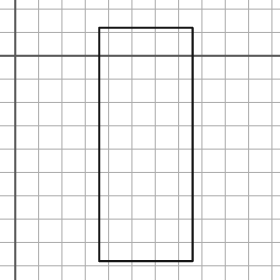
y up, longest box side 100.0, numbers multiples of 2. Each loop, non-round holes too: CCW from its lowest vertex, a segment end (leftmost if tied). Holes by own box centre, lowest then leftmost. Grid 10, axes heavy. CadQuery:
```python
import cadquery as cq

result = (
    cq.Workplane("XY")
    .moveTo(36.0, -88.0)
    .lineTo(76.0, -88.0)
    .lineTo(76.0, 12.0)
    .lineTo(36.0, 12.0)
    .close()
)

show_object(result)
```